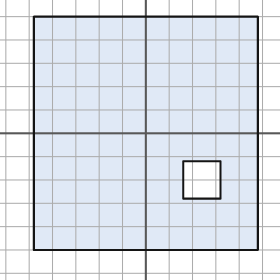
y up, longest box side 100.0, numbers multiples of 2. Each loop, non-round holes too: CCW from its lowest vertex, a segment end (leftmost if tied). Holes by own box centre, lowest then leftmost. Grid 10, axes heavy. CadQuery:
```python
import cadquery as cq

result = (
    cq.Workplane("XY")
    .moveTo(-48.0, -50.0)
    .lineTo(48.0, -50.0)
    .lineTo(48.0, 50.0)
    .lineTo(-48.0, 50.0)
    .close()
    .moveTo(16.0, -28.0)
    .lineTo(32.0, -28.0)
    .lineTo(32.0, -12.0)
    .lineTo(16.0, -12.0)
    .close()
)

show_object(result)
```